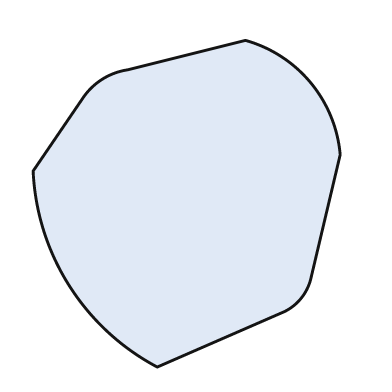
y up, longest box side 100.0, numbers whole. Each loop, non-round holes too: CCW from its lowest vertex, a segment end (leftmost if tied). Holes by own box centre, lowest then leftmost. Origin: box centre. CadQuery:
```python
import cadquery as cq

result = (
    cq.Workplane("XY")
    .moveTo(-9.0, -50.0)
    .lineTo(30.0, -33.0)
    .threePointArc((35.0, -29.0), (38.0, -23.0))
    .lineTo(47.0, 15.0)
    .threePointArc((38.0, 37.0), (18.0, 50.0))
    .lineTo(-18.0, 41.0)
    .threePointArc((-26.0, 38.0), (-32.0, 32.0))
    .lineTo(-47.0, 10.0)
    .threePointArc((-36.0, -25.0), (-9.0, -50.0))
    .close()
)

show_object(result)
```